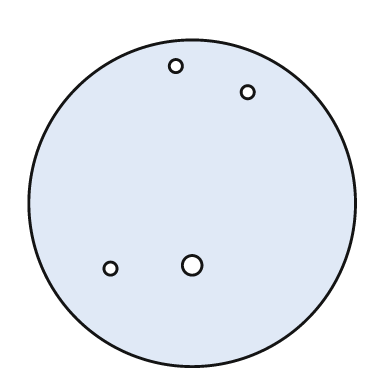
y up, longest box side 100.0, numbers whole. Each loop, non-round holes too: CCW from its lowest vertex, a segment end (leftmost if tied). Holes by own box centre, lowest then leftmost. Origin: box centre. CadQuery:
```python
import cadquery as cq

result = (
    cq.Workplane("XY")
    .moveTo(0.0, 0.0)
    .circle(50.0)
    .moveTo(-25.0, -20.0)
    .circle(2.0)
    .moveTo(0.0, -19.0)
    .circle(3.0)
    .moveTo(17.0, 34.0)
    .circle(2.0)
    .moveTo(-5.0, 42.0)
    .circle(2.0)
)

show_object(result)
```